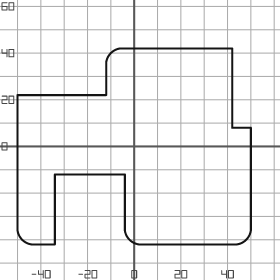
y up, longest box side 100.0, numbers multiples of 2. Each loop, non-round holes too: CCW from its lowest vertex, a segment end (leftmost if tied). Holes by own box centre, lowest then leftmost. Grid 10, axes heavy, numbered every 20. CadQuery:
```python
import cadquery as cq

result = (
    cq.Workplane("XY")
    .moveTo(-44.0, -42.0)
    .lineTo(-34.0, -42.0)
    .lineTo(-34.0, -12.0)
    .lineTo(-4.0, -12.0)
    .lineTo(-4.0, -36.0)
    .threePointArc((-2.0, -40.0), (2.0, -42.0))
    .lineTo(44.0, -42.0)
    .threePointArc((48.0, -40.0), (50.0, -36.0))
    .lineTo(50.0, 8.0)
    .lineTo(42.0, 8.0)
    .lineTo(42.0, 42.0)
    .lineTo(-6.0, 42.0)
    .threePointArc((-10.0, 40.0), (-12.0, 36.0))
    .lineTo(-12.0, 22.0)
    .lineTo(-50.0, 22.0)
    .lineTo(-50.0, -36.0)
    .threePointArc((-48.0, -40.0), (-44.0, -42.0))
    .close()
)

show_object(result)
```